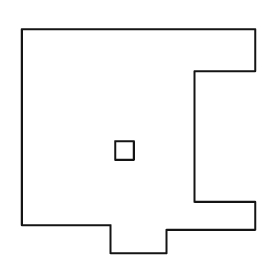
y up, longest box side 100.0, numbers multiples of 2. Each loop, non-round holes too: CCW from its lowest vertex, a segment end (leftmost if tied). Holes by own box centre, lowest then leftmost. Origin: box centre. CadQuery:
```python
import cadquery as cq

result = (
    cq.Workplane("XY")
    .moveTo(-12.0, -48.0)
    .lineTo(12.0, -48.0)
    .lineTo(12.0, -38.0)
    .lineTo(50.0, -38.0)
    .lineTo(50.0, -26.0)
    .lineTo(24.0, -26.0)
    .lineTo(24.0, 30.0)
    .lineTo(50.0, 30.0)
    .lineTo(50.0, 48.0)
    .lineTo(-50.0, 48.0)
    .lineTo(-50.0, -36.0)
    .lineTo(-12.0, -36.0)
    .close()
    .moveTo(-10.0, -8.0)
    .lineTo(-2.0, -8.0)
    .lineTo(-2.0, 0.0)
    .lineTo(-10.0, 0.0)
    .close()
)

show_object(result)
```